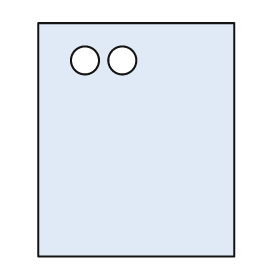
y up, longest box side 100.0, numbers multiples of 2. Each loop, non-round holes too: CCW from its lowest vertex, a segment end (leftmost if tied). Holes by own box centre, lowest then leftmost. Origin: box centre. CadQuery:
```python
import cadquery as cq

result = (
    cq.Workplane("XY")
    .moveTo(-42.0, -50.0)
    .lineTo(42.0, -50.0)
    .lineTo(42.0, 50.0)
    .lineTo(-42.0, 50.0)
    .close()
    .moveTo(-22.0, 34.0)
    .circle(6.0)
    .moveTo(-6.0, 34.0)
    .circle(6.0)
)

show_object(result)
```